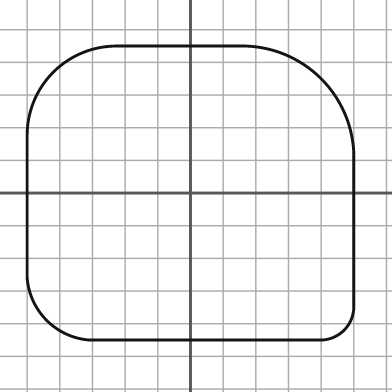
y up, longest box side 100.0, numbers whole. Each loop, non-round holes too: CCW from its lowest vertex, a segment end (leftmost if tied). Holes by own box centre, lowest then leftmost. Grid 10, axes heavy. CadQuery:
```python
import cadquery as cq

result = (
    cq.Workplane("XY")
    .moveTo(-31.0, -45.0)
    .lineTo(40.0, -45.0)
    .threePointArc((47.0, -42.0), (50.0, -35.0))
    .lineTo(50.0, 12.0)
    .threePointArc((40.0, 35.0), (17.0, 45.0))
    .lineTo(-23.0, 45.0)
    .threePointArc((-42.0, 37.0), (-50.0, 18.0))
    .lineTo(-50.0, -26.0)
    .threePointArc((-44.0, -39.0), (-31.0, -45.0))
    .close()
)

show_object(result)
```